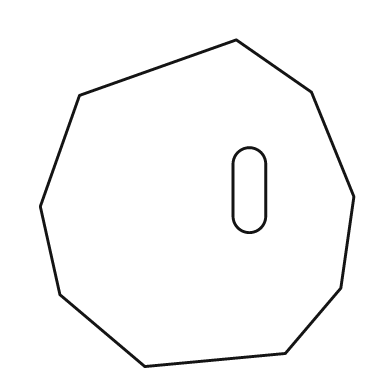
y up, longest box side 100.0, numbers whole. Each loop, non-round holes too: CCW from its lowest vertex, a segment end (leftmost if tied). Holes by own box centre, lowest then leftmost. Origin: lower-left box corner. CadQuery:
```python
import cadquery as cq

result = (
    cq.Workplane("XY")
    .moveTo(32.0, 0.0)
    .lineTo(75.0, 4.0)
    .lineTo(92.0, 24.0)
    .lineTo(96.0, 52.0)
    .lineTo(83.0, 84.0)
    .lineTo(60.0, 100.0)
    .lineTo(12.0, 83.0)
    .lineTo(0.0, 49.0)
    .lineTo(6.0, 22.0)
    .close()
    .moveTo(59.0, 46.0)
    .threePointArc((64.0, 41.0), (69.0, 46.0))
    .lineTo(69.0, 62.0)
    .threePointArc((64.0, 67.0), (59.0, 62.0))
    .close()
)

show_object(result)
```